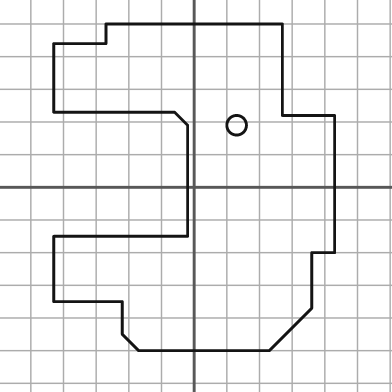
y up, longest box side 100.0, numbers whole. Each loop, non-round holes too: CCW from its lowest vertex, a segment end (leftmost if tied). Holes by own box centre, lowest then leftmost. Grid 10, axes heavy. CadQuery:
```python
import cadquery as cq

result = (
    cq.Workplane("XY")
    .moveTo(-17.0, -50.0)
    .lineTo(23.0, -50.0)
    .lineTo(36.0, -37.0)
    .lineTo(36.0, -20.0)
    .lineTo(43.0, -20.0)
    .lineTo(43.0, 22.0)
    .lineTo(27.0, 22.0)
    .lineTo(27.0, 50.0)
    .lineTo(-27.0, 50.0)
    .lineTo(-27.0, 44.0)
    .lineTo(-43.0, 44.0)
    .lineTo(-43.0, 23.0)
    .lineTo(-6.0, 23.0)
    .lineTo(-2.0, 19.0)
    .lineTo(-2.0, -15.0)
    .lineTo(-43.0, -15.0)
    .lineTo(-43.0, -35.0)
    .lineTo(-22.0, -35.0)
    .lineTo(-22.0, -45.0)
    .close()
    .moveTo(13.0, 19.0)
    .circle(3.0)
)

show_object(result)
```